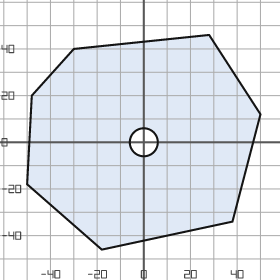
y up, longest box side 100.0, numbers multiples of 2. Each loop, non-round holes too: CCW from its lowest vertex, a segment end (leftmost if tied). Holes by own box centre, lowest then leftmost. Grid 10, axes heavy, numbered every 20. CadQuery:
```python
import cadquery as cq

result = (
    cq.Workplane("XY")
    .moveTo(-18.0, -46.0)
    .lineTo(38.0, -34.0)
    .lineTo(50.0, 12.0)
    .lineTo(28.0, 46.0)
    .lineTo(-30.0, 40.0)
    .lineTo(-48.0, 20.0)
    .lineTo(-50.0, -18.0)
    .close()
    .moveTo(0.0, 0.0)
    .circle(6.0)
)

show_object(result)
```